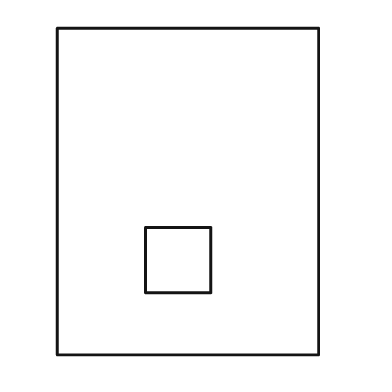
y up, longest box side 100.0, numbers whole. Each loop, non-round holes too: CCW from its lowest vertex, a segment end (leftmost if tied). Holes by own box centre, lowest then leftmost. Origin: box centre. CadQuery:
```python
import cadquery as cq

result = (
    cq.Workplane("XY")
    .moveTo(-40.0, -50.0)
    .lineTo(40.0, -50.0)
    .lineTo(40.0, 50.0)
    .lineTo(-40.0, 50.0)
    .close()
    .moveTo(-13.0, -31.0)
    .lineTo(7.0, -31.0)
    .lineTo(7.0, -11.0)
    .lineTo(-13.0, -11.0)
    .close()
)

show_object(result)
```